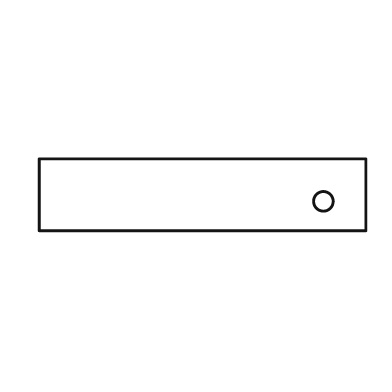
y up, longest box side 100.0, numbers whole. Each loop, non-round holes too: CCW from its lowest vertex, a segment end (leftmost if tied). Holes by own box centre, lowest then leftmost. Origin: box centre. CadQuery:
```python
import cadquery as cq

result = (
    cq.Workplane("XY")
    .moveTo(-50.0, -11.0)
    .lineTo(50.0, -11.0)
    .lineTo(50.0, 11.0)
    .lineTo(-50.0, 11.0)
    .close()
    .moveTo(37.0, -2.0)
    .circle(3.0)
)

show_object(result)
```